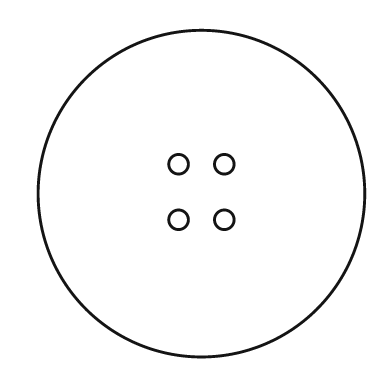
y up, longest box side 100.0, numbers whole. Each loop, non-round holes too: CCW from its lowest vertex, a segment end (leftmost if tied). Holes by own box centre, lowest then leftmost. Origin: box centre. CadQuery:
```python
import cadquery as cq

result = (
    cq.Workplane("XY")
    .moveTo(0.0, 0.0)
    .circle(50.0)
    .moveTo(-7.0, -8.0)
    .circle(3.0)
    .moveTo(7.0, -8.0)
    .circle(3.0)
    .moveTo(-7.0, 9.0)
    .circle(3.0)
    .moveTo(7.0, 9.0)
    .circle(3.0)
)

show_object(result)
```